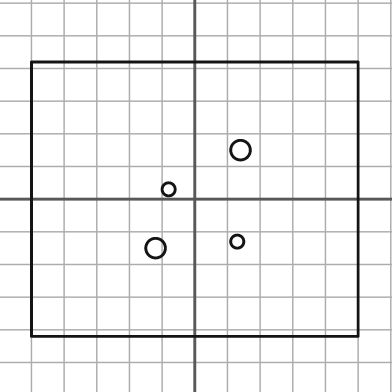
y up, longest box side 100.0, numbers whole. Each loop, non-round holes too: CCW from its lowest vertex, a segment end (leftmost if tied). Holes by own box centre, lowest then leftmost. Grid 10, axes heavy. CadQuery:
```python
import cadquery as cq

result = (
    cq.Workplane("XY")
    .moveTo(-50.0, -42.0)
    .lineTo(50.0, -42.0)
    .lineTo(50.0, 42.0)
    .lineTo(-50.0, 42.0)
    .close()
    .moveTo(-12.0, -15.0)
    .circle(3.0)
    .moveTo(13.0, -13.0)
    .circle(2.0)
    .moveTo(-8.0, 3.0)
    .circle(2.0)
    .moveTo(14.0, 15.0)
    .circle(3.0)
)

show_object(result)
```